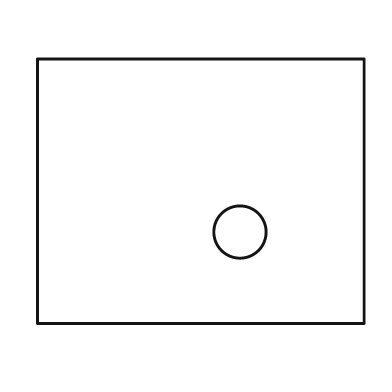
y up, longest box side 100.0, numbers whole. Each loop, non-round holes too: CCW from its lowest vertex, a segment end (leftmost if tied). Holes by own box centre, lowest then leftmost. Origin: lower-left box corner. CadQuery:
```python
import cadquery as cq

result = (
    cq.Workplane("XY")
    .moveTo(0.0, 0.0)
    .lineTo(100.0, 0.0)
    .lineTo(100.0, 81.0)
    .lineTo(0.0, 81.0)
    .close()
    .moveTo(62.0, 28.0)
    .circle(8.0)
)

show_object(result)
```